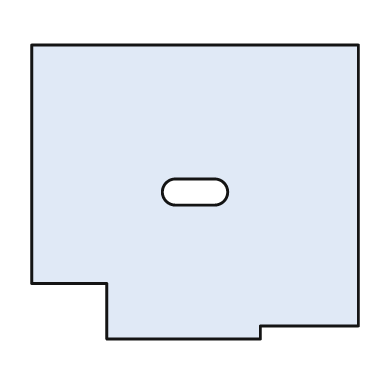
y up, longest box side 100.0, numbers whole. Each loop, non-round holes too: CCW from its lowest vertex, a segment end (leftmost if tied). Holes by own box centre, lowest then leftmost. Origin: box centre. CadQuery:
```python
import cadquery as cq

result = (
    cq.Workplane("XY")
    .moveTo(-27.0, -45.0)
    .lineTo(20.0, -45.0)
    .lineTo(20.0, -41.0)
    .lineTo(50.0, -41.0)
    .lineTo(50.0, 45.0)
    .lineTo(-50.0, 45.0)
    .lineTo(-50.0, -28.0)
    .lineTo(-27.0, -28.0)
    .close()
    .moveTo(-6.0, -4.0)
    .lineTo(6.0, -4.0)
    .threePointArc((10.0, 0.0), (6.0, 4.0))
    .lineTo(-6.0, 4.0)
    .threePointArc((-10.0, 0.0), (-6.0, -4.0))
    .close()
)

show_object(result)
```